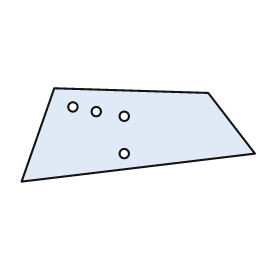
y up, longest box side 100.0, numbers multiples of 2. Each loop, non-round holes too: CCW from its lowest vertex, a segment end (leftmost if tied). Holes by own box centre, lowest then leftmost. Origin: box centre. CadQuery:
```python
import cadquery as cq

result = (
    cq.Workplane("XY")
    .moveTo(-50.0, -20.0)
    .lineTo(50.0, -8.0)
    .lineTo(30.0, 18.0)
    .lineTo(-36.0, 20.0)
    .close()
    .moveTo(-6.0, -8.0)
    .circle(2.0)
    .moveTo(-6.0, 8.0)
    .circle(2.0)
    .moveTo(-18.0, 10.0)
    .circle(2.0)
    .moveTo(-28.0, 12.0)
    .circle(2.0)
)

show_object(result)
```